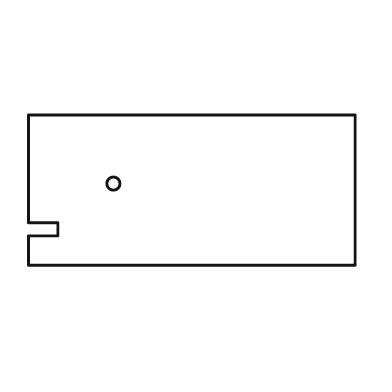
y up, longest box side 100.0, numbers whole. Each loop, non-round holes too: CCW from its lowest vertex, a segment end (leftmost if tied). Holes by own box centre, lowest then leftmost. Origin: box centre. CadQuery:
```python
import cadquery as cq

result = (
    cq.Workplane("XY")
    .moveTo(-50.0, -23.0)
    .lineTo(50.0, -23.0)
    .lineTo(50.0, 23.0)
    .lineTo(-50.0, 23.0)
    .lineTo(-50.0, -10.0)
    .lineTo(-41.0, -10.0)
    .lineTo(-41.0, -14.0)
    .lineTo(-50.0, -14.0)
    .close()
    .moveTo(-24.0, 2.0)
    .circle(2.0)
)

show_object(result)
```